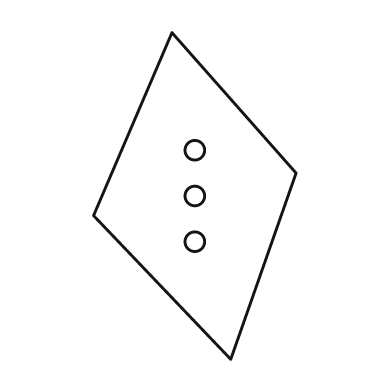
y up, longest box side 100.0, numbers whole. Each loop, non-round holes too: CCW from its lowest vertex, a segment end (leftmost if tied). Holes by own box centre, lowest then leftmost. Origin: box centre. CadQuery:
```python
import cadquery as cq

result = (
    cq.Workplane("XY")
    .moveTo(11.0, -50.0)
    .lineTo(31.0, 7.0)
    .lineTo(-7.0, 50.0)
    .lineTo(-31.0, -6.0)
    .close()
    .moveTo(0.0, -14.0)
    .circle(3.0)
    .moveTo(0.0, 0.0)
    .circle(3.0)
    .moveTo(0.0, 14.0)
    .circle(3.0)
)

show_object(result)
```